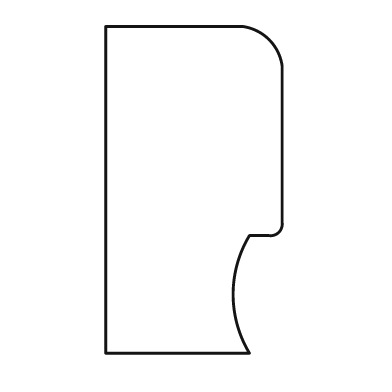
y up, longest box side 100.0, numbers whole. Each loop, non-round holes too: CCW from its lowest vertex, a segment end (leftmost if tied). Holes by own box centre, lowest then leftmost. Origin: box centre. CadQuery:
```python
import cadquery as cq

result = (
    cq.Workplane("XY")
    .moveTo(-27.0, -50.0)
    .lineTo(17.0, -50.0)
    .threePointArc((12.0, -32.0), (17.0, -14.0))
    .lineTo(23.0, -14.0)
    .threePointArc((26.0, -13.0), (27.0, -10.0))
    .lineTo(27.0, 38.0)
    .threePointArc((23.0, 46.0), (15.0, 50.0))
    .lineTo(-27.0, 50.0)
    .close()
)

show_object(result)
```